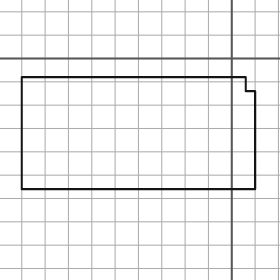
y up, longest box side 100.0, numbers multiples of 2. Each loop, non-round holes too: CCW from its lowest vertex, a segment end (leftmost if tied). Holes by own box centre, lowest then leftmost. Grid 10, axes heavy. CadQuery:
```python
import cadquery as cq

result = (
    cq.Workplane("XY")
    .moveTo(-90.0, -56.0)
    .lineTo(10.0, -56.0)
    .lineTo(10.0, -14.0)
    .lineTo(6.0, -14.0)
    .lineTo(6.0, -8.0)
    .lineTo(-90.0, -8.0)
    .close()
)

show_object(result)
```